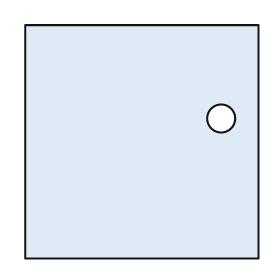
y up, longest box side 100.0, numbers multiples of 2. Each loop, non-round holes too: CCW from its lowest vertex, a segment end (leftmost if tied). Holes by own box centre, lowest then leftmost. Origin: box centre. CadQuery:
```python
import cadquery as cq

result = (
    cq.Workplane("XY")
    .moveTo(-50.0, -50.0)
    .lineTo(50.0, -50.0)
    .lineTo(50.0, 50.0)
    .lineTo(-50.0, 50.0)
    .close()
    .moveTo(34.0, 10.0)
    .circle(6.0)
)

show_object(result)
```